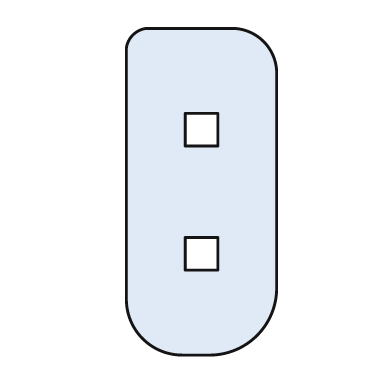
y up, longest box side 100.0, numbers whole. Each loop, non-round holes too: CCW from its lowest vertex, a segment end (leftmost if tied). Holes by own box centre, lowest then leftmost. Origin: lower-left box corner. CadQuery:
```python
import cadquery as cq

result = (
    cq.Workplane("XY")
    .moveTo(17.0, 0.0)
    .lineTo(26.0, 0.0)
    .threePointArc((40.0, 6.0), (46.0, 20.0))
    .lineTo(46.0, 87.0)
    .threePointArc((42.0, 96.0), (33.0, 100.0))
    .lineTo(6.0, 100.0)
    .threePointArc((2.0, 98.0), (0.0, 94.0))
    .lineTo(0.0, 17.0)
    .threePointArc((5.0, 5.0), (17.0, 0.0))
    .close()
    .moveTo(18.0, 26.0)
    .lineTo(28.0, 26.0)
    .lineTo(28.0, 36.0)
    .lineTo(18.0, 36.0)
    .close()
    .moveTo(18.0, 64.0)
    .lineTo(28.0, 64.0)
    .lineTo(28.0, 74.0)
    .lineTo(18.0, 74.0)
    .close()
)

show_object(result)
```